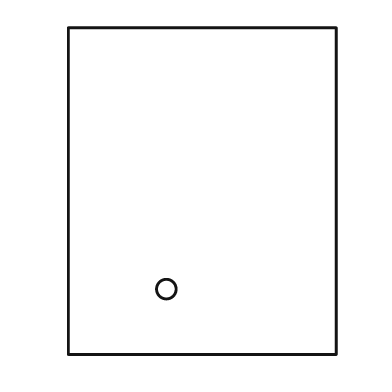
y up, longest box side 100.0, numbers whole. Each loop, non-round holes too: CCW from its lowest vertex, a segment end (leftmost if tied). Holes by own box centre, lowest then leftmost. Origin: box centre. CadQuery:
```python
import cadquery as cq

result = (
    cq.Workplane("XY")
    .moveTo(-41.0, -50.0)
    .lineTo(41.0, -50.0)
    .lineTo(41.0, 50.0)
    .lineTo(-41.0, 50.0)
    .close()
    .moveTo(-11.0, -30.0)
    .circle(3.0)
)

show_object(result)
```